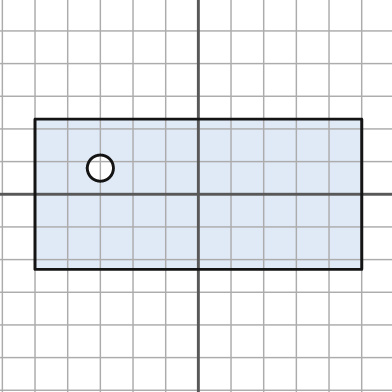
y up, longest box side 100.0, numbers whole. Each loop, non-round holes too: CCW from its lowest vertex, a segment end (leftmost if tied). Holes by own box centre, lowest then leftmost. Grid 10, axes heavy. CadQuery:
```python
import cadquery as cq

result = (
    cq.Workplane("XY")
    .moveTo(-50.0, -23.0)
    .lineTo(50.0, -23.0)
    .lineTo(50.0, 23.0)
    .lineTo(-50.0, 23.0)
    .close()
    .moveTo(-30.0, 8.0)
    .circle(4.0)
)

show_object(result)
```